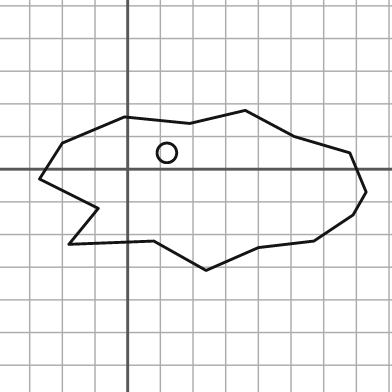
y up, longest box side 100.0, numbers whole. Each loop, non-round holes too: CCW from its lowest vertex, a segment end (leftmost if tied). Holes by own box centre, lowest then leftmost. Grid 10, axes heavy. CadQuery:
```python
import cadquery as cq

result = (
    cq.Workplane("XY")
    .moveTo(24.0, -31.0)
    .lineTo(40.0, -24.0)
    .lineTo(57.0, -22.0)
    .lineTo(69.0, -14.0)
    .lineTo(73.0, -7.0)
    .lineTo(68.0, 5.0)
    .lineTo(51.0, 10.0)
    .lineTo(36.0, 18.0)
    .lineTo(19.0, 14.0)
    .lineTo(-1.0, 16.0)
    .lineTo(-20.0, 8.0)
    .lineTo(-27.0, -3.0)
    .lineTo(-9.0, -12.0)
    .lineTo(-18.0, -23.0)
    .lineTo(8.0, -22.0)
    .close()
    .moveTo(12.0, 5.0)
    .circle(3.0)
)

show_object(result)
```